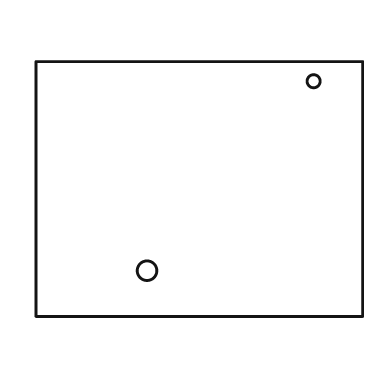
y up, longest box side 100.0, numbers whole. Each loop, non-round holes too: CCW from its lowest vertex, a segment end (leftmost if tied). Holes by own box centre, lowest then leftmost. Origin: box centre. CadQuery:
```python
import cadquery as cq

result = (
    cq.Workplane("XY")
    .moveTo(-50.0, -39.0)
    .lineTo(50.0, -39.0)
    .lineTo(50.0, 39.0)
    .lineTo(-50.0, 39.0)
    .close()
    .moveTo(-16.0, -25.0)
    .circle(3.0)
    .moveTo(35.0, 33.0)
    .circle(2.0)
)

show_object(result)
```